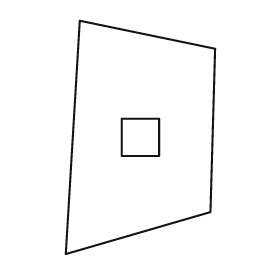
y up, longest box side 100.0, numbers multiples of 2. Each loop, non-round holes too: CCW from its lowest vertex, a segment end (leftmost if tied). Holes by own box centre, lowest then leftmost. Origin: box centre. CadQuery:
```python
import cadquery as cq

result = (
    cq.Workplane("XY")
    .moveTo(-32.0, -50.0)
    .lineTo(30.0, -32.0)
    .lineTo(32.0, 38.0)
    .lineTo(-26.0, 50.0)
    .close()
    .moveTo(-8.0, -8.0)
    .lineTo(8.0, -8.0)
    .lineTo(8.0, 8.0)
    .lineTo(-8.0, 8.0)
    .close()
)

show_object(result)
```